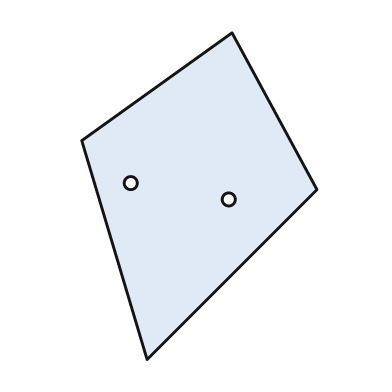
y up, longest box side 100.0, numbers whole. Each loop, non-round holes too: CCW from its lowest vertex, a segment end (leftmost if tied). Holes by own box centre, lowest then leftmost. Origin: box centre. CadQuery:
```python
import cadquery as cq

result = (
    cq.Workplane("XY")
    .moveTo(-16.0, -50.0)
    .lineTo(36.0, 2.0)
    .lineTo(10.0, 50.0)
    .lineTo(-36.0, 17.0)
    .close()
    .moveTo(9.0, -1.0)
    .circle(2.0)
    .moveTo(-21.0, 4.0)
    .circle(2.0)
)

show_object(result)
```